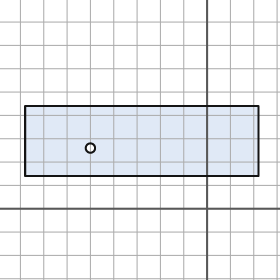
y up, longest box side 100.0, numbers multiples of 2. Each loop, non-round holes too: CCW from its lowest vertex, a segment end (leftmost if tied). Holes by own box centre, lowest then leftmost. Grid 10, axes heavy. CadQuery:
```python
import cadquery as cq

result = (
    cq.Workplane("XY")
    .moveTo(-78.0, 14.0)
    .lineTo(22.0, 14.0)
    .lineTo(22.0, 44.0)
    .lineTo(-78.0, 44.0)
    .close()
    .moveTo(-50.0, 26.0)
    .circle(2.0)
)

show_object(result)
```